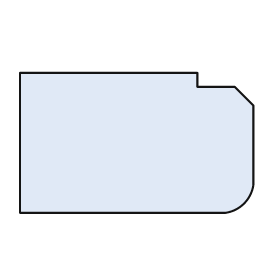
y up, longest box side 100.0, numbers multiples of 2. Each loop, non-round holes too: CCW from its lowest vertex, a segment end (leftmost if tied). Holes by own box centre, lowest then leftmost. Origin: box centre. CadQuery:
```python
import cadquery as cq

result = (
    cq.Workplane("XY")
    .moveTo(-50.0, -30.0)
    .lineTo(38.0, -30.0)
    .threePointArc((46.0, -26.0), (50.0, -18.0))
    .lineTo(50.0, 16.0)
    .lineTo(42.0, 24.0)
    .lineTo(26.0, 24.0)
    .lineTo(26.0, 30.0)
    .lineTo(-50.0, 30.0)
    .close()
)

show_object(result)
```